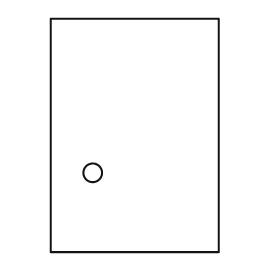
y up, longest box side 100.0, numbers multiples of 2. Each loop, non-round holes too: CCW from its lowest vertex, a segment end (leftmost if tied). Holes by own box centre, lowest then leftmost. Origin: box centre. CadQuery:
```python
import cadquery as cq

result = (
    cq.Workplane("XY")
    .moveTo(-36.0, -50.0)
    .lineTo(36.0, -50.0)
    .lineTo(36.0, 50.0)
    .lineTo(-36.0, 50.0)
    .close()
    .moveTo(-18.0, -16.0)
    .circle(4.0)
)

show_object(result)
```